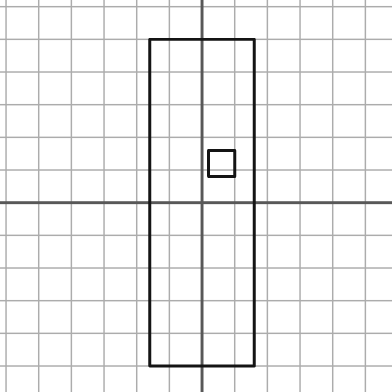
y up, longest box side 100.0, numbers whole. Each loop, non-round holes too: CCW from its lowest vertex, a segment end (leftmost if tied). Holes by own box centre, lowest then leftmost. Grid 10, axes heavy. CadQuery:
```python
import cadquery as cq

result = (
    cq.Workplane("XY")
    .moveTo(-16.0, -50.0)
    .lineTo(16.0, -50.0)
    .lineTo(16.0, 50.0)
    .lineTo(-16.0, 50.0)
    .close()
    .moveTo(2.0, 8.0)
    .lineTo(10.0, 8.0)
    .lineTo(10.0, 16.0)
    .lineTo(2.0, 16.0)
    .close()
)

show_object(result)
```